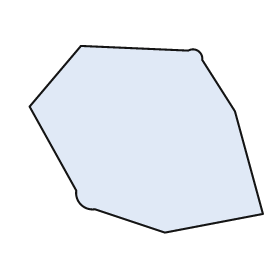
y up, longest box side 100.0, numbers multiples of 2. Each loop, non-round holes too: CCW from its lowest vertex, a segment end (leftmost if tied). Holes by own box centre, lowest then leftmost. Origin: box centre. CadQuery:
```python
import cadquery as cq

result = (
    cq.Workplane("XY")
    .moveTo(8.0, -40.0)
    .lineTo(50.0, -32.0)
    .lineTo(38.0, 12.0)
    .lineTo(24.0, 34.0)
    .threePointArc((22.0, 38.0), (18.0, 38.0))
    .lineTo(-28.0, 40.0)
    .lineTo(-50.0, 14.0)
    .lineTo(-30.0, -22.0)
    .threePointArc((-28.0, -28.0), (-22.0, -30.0))
    .close()
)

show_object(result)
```